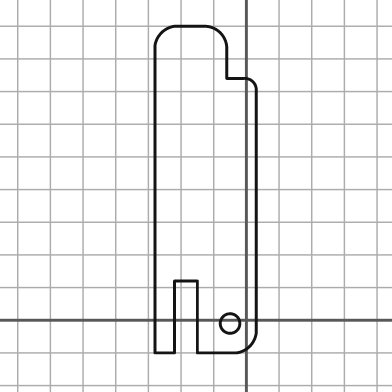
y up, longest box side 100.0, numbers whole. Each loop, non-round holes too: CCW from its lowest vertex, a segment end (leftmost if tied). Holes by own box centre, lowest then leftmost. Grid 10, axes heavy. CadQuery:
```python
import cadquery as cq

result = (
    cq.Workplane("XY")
    .moveTo(-28.0, -10.0)
    .lineTo(-22.0, -10.0)
    .lineTo(-22.0, 12.0)
    .lineTo(-15.0, 12.0)
    .lineTo(-15.0, -10.0)
    .lineTo(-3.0, -10.0)
    .threePointArc((1.0, -8.0), (3.0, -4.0))
    .lineTo(3.0, 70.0)
    .threePointArc((2.0, 73.0), (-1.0, 74.0))
    .lineTo(-6.0, 74.0)
    .lineTo(-6.0, 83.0)
    .threePointArc((-8.0, 88.0), (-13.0, 90.0))
    .lineTo(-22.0, 90.0)
    .threePointArc((-26.0, 88.0), (-28.0, 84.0))
    .close()
    .moveTo(-5.0, -1.0)
    .circle(3.0)
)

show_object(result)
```